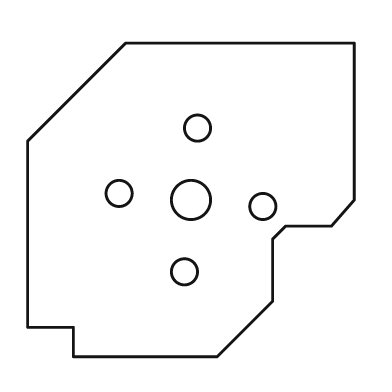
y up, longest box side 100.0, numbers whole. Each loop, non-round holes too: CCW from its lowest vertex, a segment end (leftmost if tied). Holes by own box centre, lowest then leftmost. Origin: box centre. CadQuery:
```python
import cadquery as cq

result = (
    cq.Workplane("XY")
    .moveTo(-36.0, -48.0)
    .lineTo(8.0, -48.0)
    .lineTo(25.0, -31.0)
    .lineTo(25.0, -12.0)
    .lineTo(29.0, -8.0)
    .lineTo(43.0, -8.0)
    .lineTo(50.0, 0.0)
    .lineTo(50.0, 48.0)
    .lineTo(-20.0, 48.0)
    .lineTo(-50.0, 18.0)
    .lineTo(-50.0, -39.0)
    .lineTo(-36.0, -39.0)
    .close()
    .moveTo(-2.0, -22.0)
    .circle(4.0)
    .moveTo(22.0, -2.0)
    .circle(4.0)
    .moveTo(0.0, 0.0)
    .circle(6.0)
    .moveTo(-22.0, 2.0)
    .circle(4.0)
    .moveTo(2.0, 22.0)
    .circle(4.0)
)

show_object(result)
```